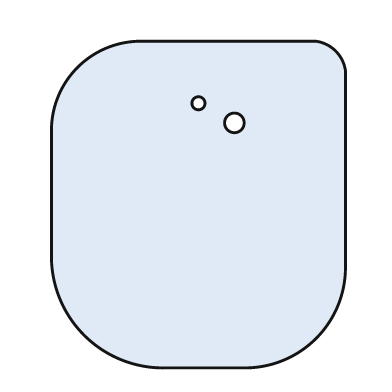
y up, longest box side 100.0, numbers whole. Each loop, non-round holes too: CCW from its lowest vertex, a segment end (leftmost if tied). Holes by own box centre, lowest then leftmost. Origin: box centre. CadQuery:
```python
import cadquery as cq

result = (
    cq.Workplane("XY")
    .moveTo(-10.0, -50.0)
    .lineTo(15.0, -50.0)
    .threePointArc((36.0, -41.0), (45.0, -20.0))
    .lineTo(45.0, 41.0)
    .threePointArc((42.0, 47.0), (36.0, 50.0))
    .lineTo(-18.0, 50.0)
    .threePointArc((-37.0, 42.0), (-45.0, 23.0))
    .lineTo(-45.0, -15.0)
    .threePointArc((-35.0, -40.0), (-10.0, -50.0))
    .close()
    .moveTo(11.0, 25.0)
    .circle(3.0)
    .moveTo(0.0, 31.0)
    .circle(2.0)
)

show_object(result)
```